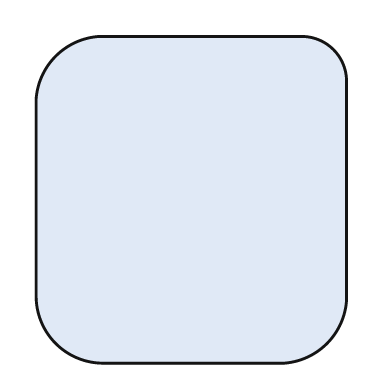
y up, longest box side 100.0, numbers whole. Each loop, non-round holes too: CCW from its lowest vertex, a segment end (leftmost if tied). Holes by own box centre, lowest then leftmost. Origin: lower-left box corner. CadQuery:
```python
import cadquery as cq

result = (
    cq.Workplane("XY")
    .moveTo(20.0, 0.0)
    .lineTo(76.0, 0.0)
    .threePointArc((89.0, 6.0), (95.0, 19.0))
    .lineTo(95.0, 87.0)
    .threePointArc((91.0, 96.0), (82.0, 100.0))
    .lineTo(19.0, 100.0)
    .threePointArc((6.0, 94.0), (0.0, 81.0))
    .lineTo(0.0, 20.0)
    .threePointArc((6.0, 6.0), (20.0, 0.0))
    .close()
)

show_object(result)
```